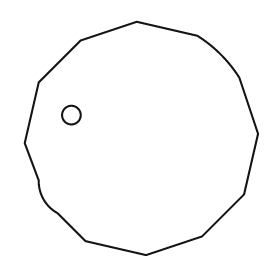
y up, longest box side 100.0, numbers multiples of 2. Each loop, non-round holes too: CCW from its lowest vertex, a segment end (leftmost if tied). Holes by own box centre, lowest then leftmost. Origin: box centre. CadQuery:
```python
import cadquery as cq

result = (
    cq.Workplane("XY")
    .moveTo(2.0, -50.0)
    .lineTo(26.0, -42.0)
    .lineTo(44.0, -24.0)
    .lineTo(50.0, 2.0)
    .lineTo(42.0, 26.0)
    .threePointArc((34.0, 36.0), (24.0, 44.0))
    .lineTo(-2.0, 50.0)
    .lineTo(-26.0, 42.0)
    .lineTo(-44.0, 24.0)
    .lineTo(-50.0, -2.0)
    .lineTo(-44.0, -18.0)
    .threePointArc((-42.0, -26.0), (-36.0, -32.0))
    .lineTo(-24.0, -44.0)
    .close()
    .moveTo(-30.0, 10.0)
    .circle(4.0)
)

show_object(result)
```